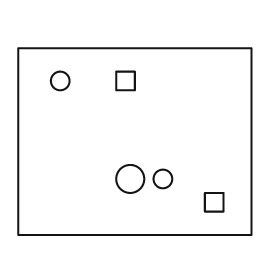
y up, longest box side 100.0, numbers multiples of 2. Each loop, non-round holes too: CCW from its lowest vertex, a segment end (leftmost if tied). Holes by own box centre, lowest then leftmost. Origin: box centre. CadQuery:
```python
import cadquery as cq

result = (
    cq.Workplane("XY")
    .moveTo(-50.0, -40.0)
    .lineTo(50.0, -40.0)
    .lineTo(50.0, 40.0)
    .lineTo(-50.0, 40.0)
    .close()
    .moveTo(30.0, -30.0)
    .lineTo(38.0, -30.0)
    .lineTo(38.0, -22.0)
    .lineTo(30.0, -22.0)
    .close()
    .moveTo(-2.0, -16.0)
    .circle(6.0)
    .moveTo(12.0, -16.0)
    .circle(4.0)
    .moveTo(-32.0, 26.0)
    .circle(4.0)
    .moveTo(-8.0, 22.0)
    .lineTo(0.0, 22.0)
    .lineTo(0.0, 30.0)
    .lineTo(-8.0, 30.0)
    .close()
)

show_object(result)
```